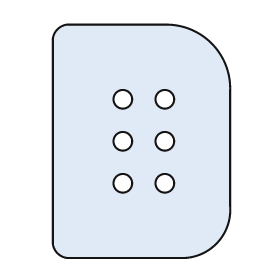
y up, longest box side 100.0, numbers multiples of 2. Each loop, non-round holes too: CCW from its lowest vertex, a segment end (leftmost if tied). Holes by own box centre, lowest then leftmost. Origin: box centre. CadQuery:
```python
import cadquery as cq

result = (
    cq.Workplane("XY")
    .moveTo(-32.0, -50.0)
    .lineTo(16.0, -50.0)
    .threePointArc((32.0, -44.0), (38.0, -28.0))
    .lineTo(38.0, 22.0)
    .threePointArc((30.0, 42.0), (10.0, 50.0))
    .lineTo(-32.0, 50.0)
    .threePointArc((-36.0, 48.0), (-38.0, 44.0))
    .lineTo(-38.0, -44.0)
    .threePointArc((-36.0, -48.0), (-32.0, -50.0))
    .close()
    .moveTo(-8.0, -18.0)
    .circle(4.0)
    .moveTo(10.0, -18.0)
    .circle(4.0)
    .moveTo(-8.0, 0.0)
    .circle(4.0)
    .moveTo(10.0, 0.0)
    .circle(4.0)
    .moveTo(-8.0, 18.0)
    .circle(4.0)
    .moveTo(10.0, 18.0)
    .circle(4.0)
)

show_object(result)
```